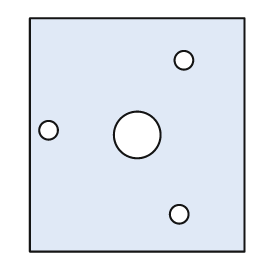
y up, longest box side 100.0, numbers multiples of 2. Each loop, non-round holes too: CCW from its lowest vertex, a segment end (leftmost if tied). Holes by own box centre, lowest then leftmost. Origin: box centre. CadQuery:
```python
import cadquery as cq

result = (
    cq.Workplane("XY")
    .moveTo(-46.0, -50.0)
    .lineTo(46.0, -50.0)
    .lineTo(46.0, 50.0)
    .lineTo(-46.0, 50.0)
    .close()
    .moveTo(18.0, -34.0)
    .circle(4.0)
    .moveTo(0.0, 0.0)
    .circle(10.0)
    .moveTo(-38.0, 2.0)
    .circle(4.0)
    .moveTo(20.0, 32.0)
    .circle(4.0)
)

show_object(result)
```